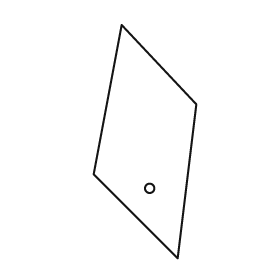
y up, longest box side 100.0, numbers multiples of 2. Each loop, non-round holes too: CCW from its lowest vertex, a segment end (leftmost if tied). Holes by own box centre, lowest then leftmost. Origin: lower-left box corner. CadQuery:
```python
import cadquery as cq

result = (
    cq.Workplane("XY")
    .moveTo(36.0, 0.0)
    .lineTo(44.0, 66.0)
    .lineTo(12.0, 100.0)
    .lineTo(0.0, 36.0)
    .close()
    .moveTo(24.0, 30.0)
    .circle(2.0)
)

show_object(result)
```